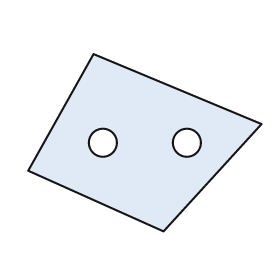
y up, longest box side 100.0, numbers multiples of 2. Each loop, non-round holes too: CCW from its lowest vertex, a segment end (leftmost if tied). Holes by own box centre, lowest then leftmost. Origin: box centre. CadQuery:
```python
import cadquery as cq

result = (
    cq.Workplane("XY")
    .moveTo(8.0, -38.0)
    .lineTo(50.0, 8.0)
    .lineTo(-22.0, 38.0)
    .lineTo(-50.0, -12.0)
    .close()
    .moveTo(-18.0, 0.0)
    .circle(6.0)
    .moveTo(18.0, 0.0)
    .circle(6.0)
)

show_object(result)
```